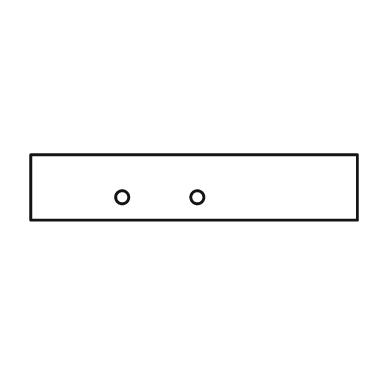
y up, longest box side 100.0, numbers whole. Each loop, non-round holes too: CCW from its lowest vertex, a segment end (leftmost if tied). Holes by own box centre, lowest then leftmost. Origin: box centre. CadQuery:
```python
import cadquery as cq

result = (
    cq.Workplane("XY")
    .moveTo(-50.0, -10.0)
    .lineTo(50.0, -10.0)
    .lineTo(50.0, 10.0)
    .lineTo(-50.0, 10.0)
    .close()
    .moveTo(-22.0, -3.0)
    .circle(2.0)
    .moveTo(1.0, -3.0)
    .circle(2.0)
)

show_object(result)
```